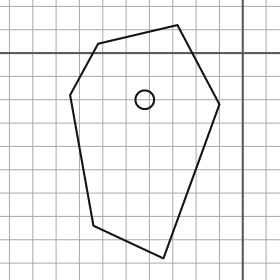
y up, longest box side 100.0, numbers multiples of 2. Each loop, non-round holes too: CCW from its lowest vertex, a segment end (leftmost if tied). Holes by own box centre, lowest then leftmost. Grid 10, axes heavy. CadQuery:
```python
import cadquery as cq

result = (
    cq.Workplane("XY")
    .moveTo(-34.0, -88.0)
    .lineTo(-10.0, -22.0)
    .lineTo(-28.0, 12.0)
    .lineTo(-62.0, 4.0)
    .lineTo(-74.0, -18.0)
    .lineTo(-64.0, -74.0)
    .close()
    .moveTo(-42.0, -20.0)
    .circle(4.0)
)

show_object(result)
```